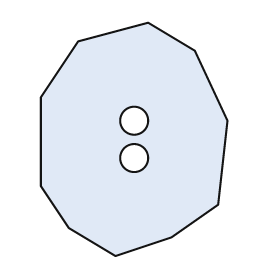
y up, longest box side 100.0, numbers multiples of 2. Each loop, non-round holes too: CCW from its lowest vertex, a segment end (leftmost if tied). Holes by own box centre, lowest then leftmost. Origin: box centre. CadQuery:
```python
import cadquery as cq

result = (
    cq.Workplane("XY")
    .moveTo(-8.0, -50.0)
    .lineTo(16.0, -42.0)
    .lineTo(36.0, -28.0)
    .lineTo(40.0, 8.0)
    .lineTo(26.0, 38.0)
    .lineTo(6.0, 50.0)
    .lineTo(-24.0, 42.0)
    .lineTo(-40.0, 18.0)
    .lineTo(-40.0, -20.0)
    .lineTo(-28.0, -38.0)
    .close()
    .moveTo(0.0, -8.0)
    .circle(6.0)
    .moveTo(0.0, 8.0)
    .circle(6.0)
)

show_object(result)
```